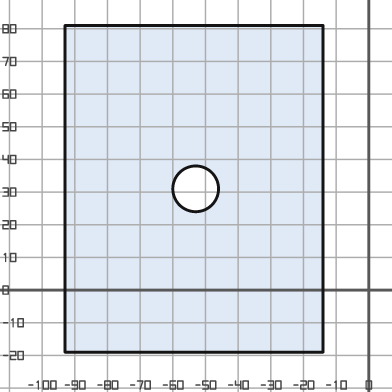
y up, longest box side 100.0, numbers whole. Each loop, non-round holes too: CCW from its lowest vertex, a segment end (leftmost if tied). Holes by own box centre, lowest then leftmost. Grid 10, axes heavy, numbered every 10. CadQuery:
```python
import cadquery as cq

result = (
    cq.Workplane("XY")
    .moveTo(-93.0, -19.0)
    .lineTo(-14.0, -19.0)
    .lineTo(-14.0, 81.0)
    .lineTo(-93.0, 81.0)
    .close()
    .moveTo(-53.0, 31.0)
    .circle(7.0)
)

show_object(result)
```